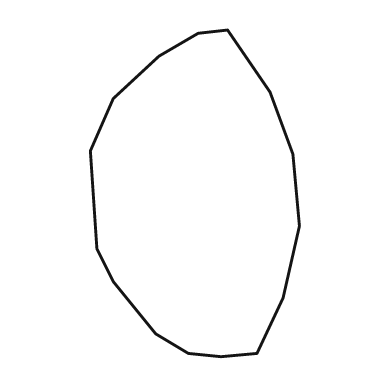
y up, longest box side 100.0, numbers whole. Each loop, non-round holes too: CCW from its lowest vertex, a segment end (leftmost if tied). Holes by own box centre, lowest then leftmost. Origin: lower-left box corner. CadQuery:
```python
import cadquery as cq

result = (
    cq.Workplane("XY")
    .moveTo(40.0, 0.0)
    .lineTo(51.0, 1.0)
    .lineTo(59.0, 18.0)
    .lineTo(64.0, 40.0)
    .lineTo(62.0, 62.0)
    .lineTo(55.0, 81.0)
    .lineTo(42.0, 100.0)
    .lineTo(33.0, 99.0)
    .lineTo(21.0, 92.0)
    .lineTo(7.0, 79.0)
    .lineTo(0.0, 63.0)
    .lineTo(2.0, 33.0)
    .lineTo(7.0, 23.0)
    .lineTo(20.0, 7.0)
    .lineTo(30.0, 1.0)
    .close()
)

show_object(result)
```